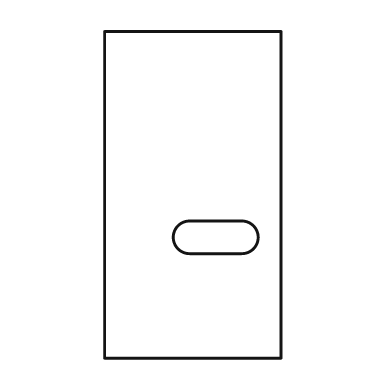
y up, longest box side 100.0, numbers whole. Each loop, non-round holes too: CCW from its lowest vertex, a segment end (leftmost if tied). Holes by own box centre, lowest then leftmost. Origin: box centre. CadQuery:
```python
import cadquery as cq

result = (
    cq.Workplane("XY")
    .moveTo(-27.0, -50.0)
    .lineTo(27.0, -50.0)
    .lineTo(27.0, 50.0)
    .lineTo(-27.0, 50.0)
    .close()
    .moveTo(-1.0, -18.0)
    .lineTo(15.0, -18.0)
    .threePointArc((20.0, -13.0), (15.0, -8.0))
    .lineTo(-1.0, -8.0)
    .threePointArc((-6.0, -13.0), (-1.0, -18.0))
    .close()
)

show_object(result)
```